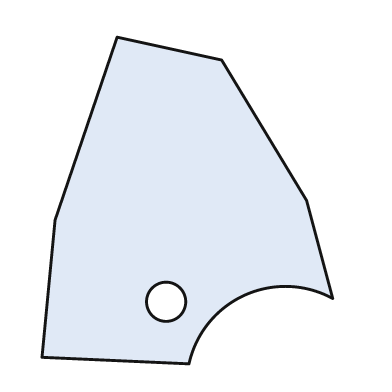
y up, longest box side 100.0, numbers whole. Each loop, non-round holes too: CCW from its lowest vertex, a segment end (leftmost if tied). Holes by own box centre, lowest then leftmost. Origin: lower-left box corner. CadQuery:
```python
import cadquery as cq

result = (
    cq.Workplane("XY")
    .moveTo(45.0, 0.0)
    .threePointArc((62.0, 21.0), (89.0, 20.0))
    .lineTo(81.0, 50.0)
    .lineTo(55.0, 93.0)
    .lineTo(23.0, 100.0)
    .lineTo(4.0, 44.0)
    .lineTo(0.0, 2.0)
    .close()
    .moveTo(38.0, 19.0)
    .circle(6.0)
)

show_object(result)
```